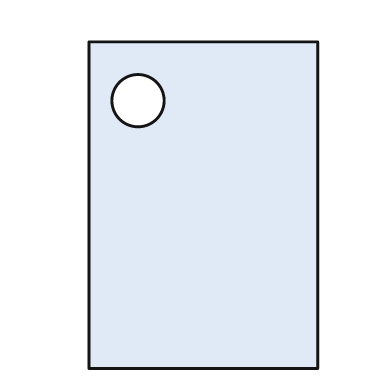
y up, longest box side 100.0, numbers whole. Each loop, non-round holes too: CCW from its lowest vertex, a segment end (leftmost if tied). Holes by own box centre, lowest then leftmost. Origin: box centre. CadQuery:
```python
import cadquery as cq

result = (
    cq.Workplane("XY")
    .moveTo(-35.0, -50.0)
    .lineTo(35.0, -50.0)
    .lineTo(35.0, 50.0)
    .lineTo(-35.0, 50.0)
    .close()
    .moveTo(-20.0, 32.0)
    .circle(8.0)
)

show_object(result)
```